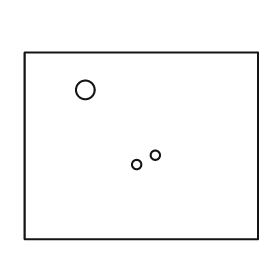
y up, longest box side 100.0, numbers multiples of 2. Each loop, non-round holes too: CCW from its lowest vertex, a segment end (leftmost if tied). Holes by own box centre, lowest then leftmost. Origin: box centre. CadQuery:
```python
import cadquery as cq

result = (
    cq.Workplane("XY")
    .moveTo(-50.0, -40.0)
    .lineTo(50.0, -40.0)
    .lineTo(50.0, 40.0)
    .lineTo(-50.0, 40.0)
    .close()
    .moveTo(-2.0, -8.0)
    .circle(2.0)
    .moveTo(6.0, -4.0)
    .circle(2.0)
    .moveTo(-24.0, 24.0)
    .circle(4.0)
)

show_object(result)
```